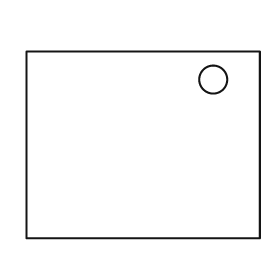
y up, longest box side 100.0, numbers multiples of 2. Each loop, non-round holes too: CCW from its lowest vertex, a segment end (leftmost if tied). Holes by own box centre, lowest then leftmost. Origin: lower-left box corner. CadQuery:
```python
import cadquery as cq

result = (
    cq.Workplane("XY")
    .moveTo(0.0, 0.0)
    .lineTo(100.0, 0.0)
    .lineTo(100.0, 80.0)
    .lineTo(0.0, 80.0)
    .close()
    .moveTo(80.0, 68.0)
    .circle(6.0)
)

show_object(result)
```